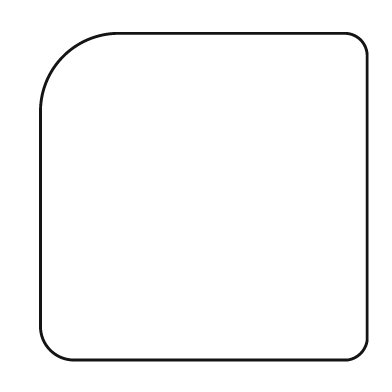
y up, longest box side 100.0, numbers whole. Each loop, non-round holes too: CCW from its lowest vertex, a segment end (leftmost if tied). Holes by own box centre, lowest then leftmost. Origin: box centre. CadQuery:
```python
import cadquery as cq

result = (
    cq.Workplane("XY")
    .moveTo(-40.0, -50.0)
    .lineTo(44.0, -50.0)
    .threePointArc((48.0, -48.0), (50.0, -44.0))
    .lineTo(50.0, 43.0)
    .threePointArc((48.0, 48.0), (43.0, 50.0))
    .lineTo(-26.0, 50.0)
    .threePointArc((-43.0, 43.0), (-50.0, 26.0))
    .lineTo(-50.0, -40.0)
    .threePointArc((-47.0, -47.0), (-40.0, -50.0))
    .close()
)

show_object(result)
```